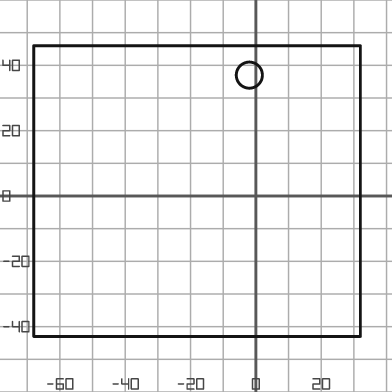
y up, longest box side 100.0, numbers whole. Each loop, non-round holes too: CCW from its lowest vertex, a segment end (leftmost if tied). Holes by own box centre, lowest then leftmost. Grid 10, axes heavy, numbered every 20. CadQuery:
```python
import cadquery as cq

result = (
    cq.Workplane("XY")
    .moveTo(-68.0, -43.0)
    .lineTo(32.0, -43.0)
    .lineTo(32.0, 46.0)
    .lineTo(-68.0, 46.0)
    .close()
    .moveTo(-2.0, 37.0)
    .circle(4.0)
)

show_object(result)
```